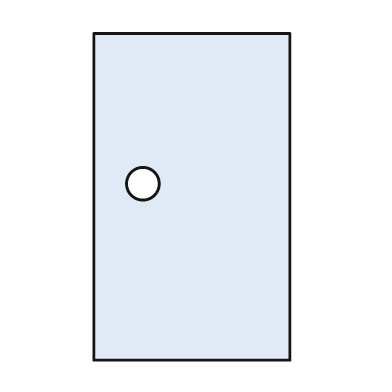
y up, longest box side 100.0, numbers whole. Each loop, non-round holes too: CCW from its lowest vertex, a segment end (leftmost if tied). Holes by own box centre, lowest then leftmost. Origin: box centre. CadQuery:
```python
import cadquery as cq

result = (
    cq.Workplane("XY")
    .moveTo(-30.0, -50.0)
    .lineTo(30.0, -50.0)
    .lineTo(30.0, 50.0)
    .lineTo(-30.0, 50.0)
    .close()
    .moveTo(-15.0, 4.0)
    .circle(5.0)
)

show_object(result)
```